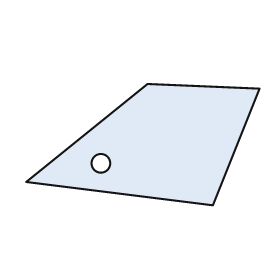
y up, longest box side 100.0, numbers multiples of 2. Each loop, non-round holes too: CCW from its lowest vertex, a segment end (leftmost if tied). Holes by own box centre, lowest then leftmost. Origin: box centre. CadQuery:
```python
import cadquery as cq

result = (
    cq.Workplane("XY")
    .moveTo(30.0, -26.0)
    .lineTo(50.0, 24.0)
    .lineTo(2.0, 26.0)
    .lineTo(-50.0, -16.0)
    .close()
    .moveTo(-18.0, -8.0)
    .circle(4.0)
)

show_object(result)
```